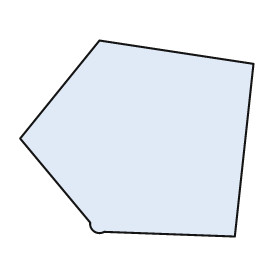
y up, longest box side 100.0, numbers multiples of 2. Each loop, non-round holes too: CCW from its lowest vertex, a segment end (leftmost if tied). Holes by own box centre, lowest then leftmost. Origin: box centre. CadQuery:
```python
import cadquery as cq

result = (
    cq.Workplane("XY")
    .moveTo(42.0, -42.0)
    .lineTo(50.0, 32.0)
    .lineTo(-16.0, 42.0)
    .lineTo(-50.0, 0.0)
    .lineTo(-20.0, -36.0)
    .threePointArc((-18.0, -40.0), (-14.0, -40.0))
    .close()
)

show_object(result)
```